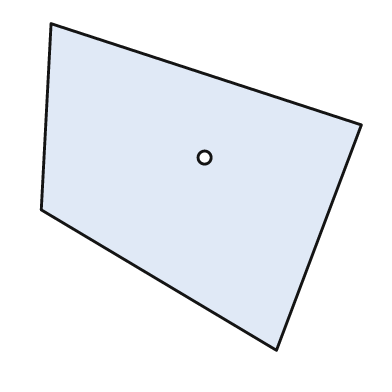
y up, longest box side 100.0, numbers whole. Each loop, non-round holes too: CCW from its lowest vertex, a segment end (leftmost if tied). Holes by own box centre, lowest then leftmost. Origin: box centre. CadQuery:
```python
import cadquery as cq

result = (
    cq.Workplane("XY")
    .moveTo(23.0, -50.0)
    .lineTo(49.0, 19.0)
    .lineTo(-46.0, 50.0)
    .lineTo(-49.0, -7.0)
    .close()
    .moveTo(1.0, 9.0)
    .circle(2.0)
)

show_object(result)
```